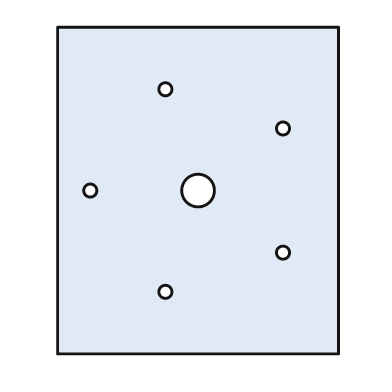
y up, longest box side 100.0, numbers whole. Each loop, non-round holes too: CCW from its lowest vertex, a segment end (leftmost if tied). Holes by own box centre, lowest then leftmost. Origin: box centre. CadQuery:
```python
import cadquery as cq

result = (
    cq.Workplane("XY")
    .moveTo(-43.0, -50.0)
    .lineTo(43.0, -50.0)
    .lineTo(43.0, 50.0)
    .lineTo(-43.0, 50.0)
    .close()
    .moveTo(-10.0, -31.0)
    .circle(2.0)
    .moveTo(26.0, -19.0)
    .circle(2.0)
    .moveTo(-33.0, 0.0)
    .circle(2.0)
    .moveTo(0.0, 0.0)
    .circle(5.0)
    .moveTo(26.0, 19.0)
    .circle(2.0)
    .moveTo(-10.0, 31.0)
    .circle(2.0)
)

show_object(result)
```